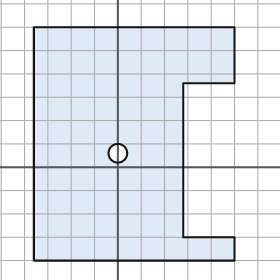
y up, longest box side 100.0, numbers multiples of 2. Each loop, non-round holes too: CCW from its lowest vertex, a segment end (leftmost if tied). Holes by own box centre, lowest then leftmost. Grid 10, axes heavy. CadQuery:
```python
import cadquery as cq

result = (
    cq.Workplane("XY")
    .moveTo(-36.0, -40.0)
    .lineTo(50.0, -40.0)
    .lineTo(50.0, -30.0)
    .lineTo(28.0, -30.0)
    .lineTo(28.0, 36.0)
    .lineTo(50.0, 36.0)
    .lineTo(50.0, 60.0)
    .lineTo(-36.0, 60.0)
    .close()
    .moveTo(0.0, 6.0)
    .circle(4.0)
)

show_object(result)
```